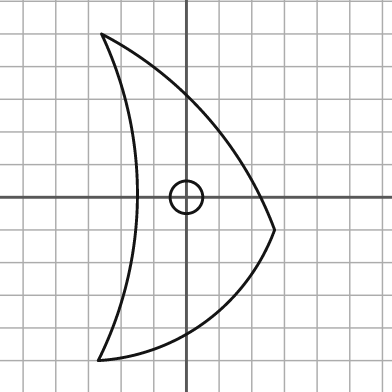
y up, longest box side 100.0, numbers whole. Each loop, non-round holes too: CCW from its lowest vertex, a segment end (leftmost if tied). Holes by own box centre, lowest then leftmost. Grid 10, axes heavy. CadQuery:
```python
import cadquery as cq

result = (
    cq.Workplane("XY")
    .moveTo(-27.0, -50.0)
    .threePointArc((6.0, -38.0), (27.0, -10.0))
    .threePointArc((6.0, 25.0), (-26.0, 50.0))
    .threePointArc((-15.0, 0.0), (-27.0, -50.0))
    .close()
    .moveTo(0.0, 0.0)
    .circle(5.0)
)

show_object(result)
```